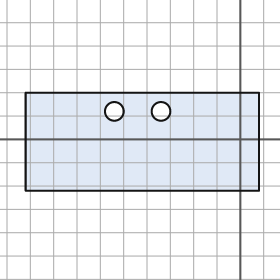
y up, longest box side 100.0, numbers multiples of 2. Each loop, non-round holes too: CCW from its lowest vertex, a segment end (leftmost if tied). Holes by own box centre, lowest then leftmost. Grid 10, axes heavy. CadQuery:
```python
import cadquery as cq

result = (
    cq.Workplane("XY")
    .moveTo(-92.0, -22.0)
    .lineTo(8.0, -22.0)
    .lineTo(8.0, 20.0)
    .lineTo(-92.0, 20.0)
    .close()
    .moveTo(-54.0, 12.0)
    .circle(4.0)
    .moveTo(-34.0, 12.0)
    .circle(4.0)
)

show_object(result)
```